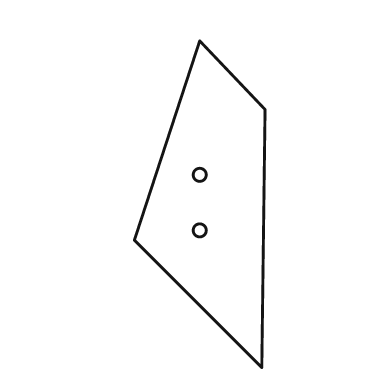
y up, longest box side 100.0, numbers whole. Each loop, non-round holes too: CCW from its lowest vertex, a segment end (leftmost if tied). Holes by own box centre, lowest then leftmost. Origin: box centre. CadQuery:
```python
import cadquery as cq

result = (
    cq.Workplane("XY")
    .moveTo(19.0, -50.0)
    .lineTo(20.0, 29.0)
    .lineTo(0.0, 50.0)
    .lineTo(-20.0, -11.0)
    .close()
    .moveTo(0.0, -8.0)
    .circle(2.0)
    .moveTo(0.0, 9.0)
    .circle(2.0)
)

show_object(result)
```